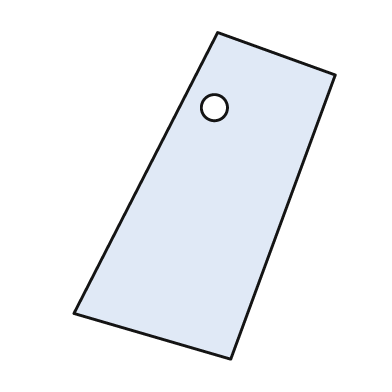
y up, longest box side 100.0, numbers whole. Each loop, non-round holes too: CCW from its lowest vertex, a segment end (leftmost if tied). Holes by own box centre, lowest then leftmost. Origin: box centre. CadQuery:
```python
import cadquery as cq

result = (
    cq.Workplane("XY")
    .moveTo(8.0, -50.0)
    .lineTo(40.0, 37.0)
    .lineTo(4.0, 50.0)
    .lineTo(-40.0, -36.0)
    .close()
    .moveTo(3.0, 27.0)
    .circle(4.0)
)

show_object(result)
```